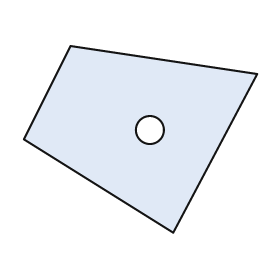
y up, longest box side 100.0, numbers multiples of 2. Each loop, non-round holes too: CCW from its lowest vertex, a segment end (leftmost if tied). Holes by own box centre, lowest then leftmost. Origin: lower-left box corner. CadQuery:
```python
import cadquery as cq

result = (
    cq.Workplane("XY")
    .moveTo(64.0, 0.0)
    .lineTo(100.0, 68.0)
    .lineTo(20.0, 80.0)
    .lineTo(0.0, 40.0)
    .close()
    .moveTo(54.0, 44.0)
    .circle(6.0)
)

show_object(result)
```